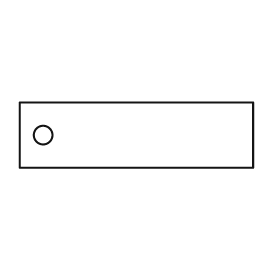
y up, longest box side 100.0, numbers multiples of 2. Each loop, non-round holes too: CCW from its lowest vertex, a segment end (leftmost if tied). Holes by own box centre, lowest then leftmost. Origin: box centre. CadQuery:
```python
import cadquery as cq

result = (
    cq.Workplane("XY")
    .moveTo(-50.0, -14.0)
    .lineTo(50.0, -14.0)
    .lineTo(50.0, 14.0)
    .lineTo(-50.0, 14.0)
    .close()
    .moveTo(-40.0, 0.0)
    .circle(4.0)
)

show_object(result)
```